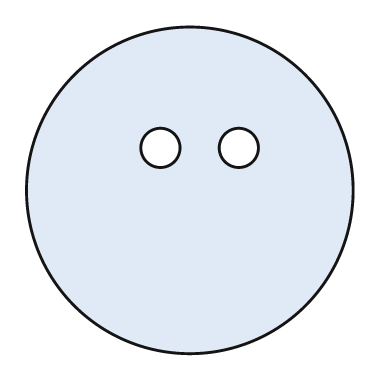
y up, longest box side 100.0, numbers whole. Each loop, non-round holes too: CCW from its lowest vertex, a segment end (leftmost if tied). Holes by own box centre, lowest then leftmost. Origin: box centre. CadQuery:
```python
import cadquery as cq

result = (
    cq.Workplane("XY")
    .moveTo(0.0, 0.0)
    .circle(50.0)
    .moveTo(-9.0, 13.0)
    .circle(6.0)
    .moveTo(15.0, 13.0)
    .circle(6.0)
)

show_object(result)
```